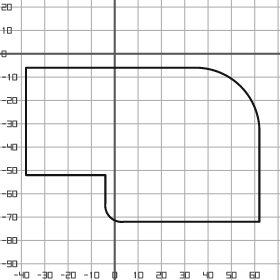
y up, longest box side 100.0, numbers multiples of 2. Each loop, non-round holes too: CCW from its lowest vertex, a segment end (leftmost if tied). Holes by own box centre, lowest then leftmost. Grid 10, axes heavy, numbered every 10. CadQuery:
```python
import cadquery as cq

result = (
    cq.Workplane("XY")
    .moveTo(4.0, -72.0)
    .lineTo(62.0, -72.0)
    .lineTo(62.0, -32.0)
    .threePointArc((54.0, -14.0), (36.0, -6.0))
    .lineTo(-38.0, -6.0)
    .lineTo(-38.0, -52.0)
    .lineTo(-4.0, -52.0)
    .lineTo(-4.0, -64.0)
    .threePointArc((-2.0, -70.0), (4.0, -72.0))
    .close()
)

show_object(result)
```